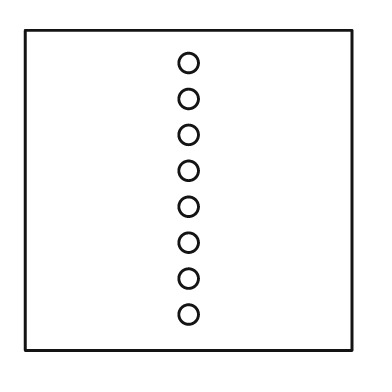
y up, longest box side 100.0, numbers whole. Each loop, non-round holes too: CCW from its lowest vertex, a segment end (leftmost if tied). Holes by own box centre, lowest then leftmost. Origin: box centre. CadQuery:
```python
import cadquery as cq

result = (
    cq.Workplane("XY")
    .moveTo(-50.0, -49.0)
    .lineTo(50.0, -49.0)
    .lineTo(50.0, 49.0)
    .lineTo(-50.0, 49.0)
    .close()
    .moveTo(0.0, -38.0)
    .circle(3.0)
    .moveTo(0.0, -27.0)
    .circle(3.0)
    .moveTo(0.0, -16.0)
    .circle(3.0)
    .moveTo(0.0, -5.0)
    .circle(3.0)
    .moveTo(0.0, 6.0)
    .circle(3.0)
    .moveTo(0.0, 17.0)
    .circle(3.0)
    .moveTo(0.0, 28.0)
    .circle(3.0)
    .moveTo(0.0, 39.0)
    .circle(3.0)
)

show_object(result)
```